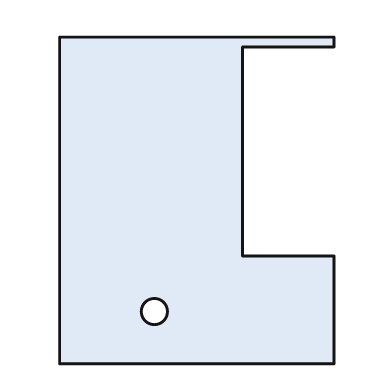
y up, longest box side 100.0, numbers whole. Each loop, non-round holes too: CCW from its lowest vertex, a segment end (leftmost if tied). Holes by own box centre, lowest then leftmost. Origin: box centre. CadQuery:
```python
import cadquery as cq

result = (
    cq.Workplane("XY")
    .moveTo(-42.0, -50.0)
    .lineTo(42.0, -50.0)
    .lineTo(42.0, -17.0)
    .lineTo(14.0, -17.0)
    .lineTo(14.0, 47.0)
    .lineTo(42.0, 47.0)
    .lineTo(42.0, 50.0)
    .lineTo(-42.0, 50.0)
    .close()
    .moveTo(-13.0, -34.0)
    .circle(4.0)
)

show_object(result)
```